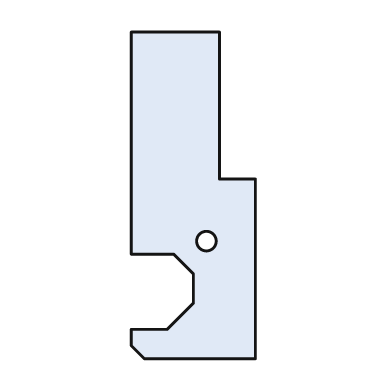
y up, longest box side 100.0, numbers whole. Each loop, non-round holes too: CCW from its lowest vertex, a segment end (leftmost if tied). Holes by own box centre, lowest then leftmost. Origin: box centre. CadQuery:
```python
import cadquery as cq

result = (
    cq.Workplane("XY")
    .moveTo(-15.0, -50.0)
    .lineTo(19.0, -50.0)
    .lineTo(19.0, 5.0)
    .lineTo(8.0, 5.0)
    .lineTo(8.0, 50.0)
    .lineTo(-19.0, 50.0)
    .lineTo(-19.0, -18.0)
    .lineTo(-6.0, -18.0)
    .lineTo(0.0, -24.0)
    .lineTo(0.0, -33.0)
    .lineTo(-8.0, -41.0)
    .lineTo(-19.0, -41.0)
    .lineTo(-19.0, -46.0)
    .close()
    .moveTo(4.0, -14.0)
    .circle(3.0)
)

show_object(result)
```